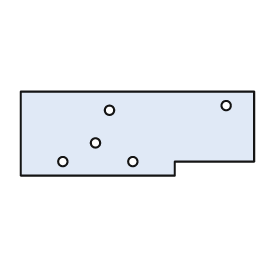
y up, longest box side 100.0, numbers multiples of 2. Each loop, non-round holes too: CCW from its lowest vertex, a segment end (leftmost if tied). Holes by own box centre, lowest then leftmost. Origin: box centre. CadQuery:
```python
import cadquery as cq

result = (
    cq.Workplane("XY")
    .moveTo(-50.0, -18.0)
    .lineTo(16.0, -18.0)
    .lineTo(16.0, -12.0)
    .lineTo(50.0, -12.0)
    .lineTo(50.0, 18.0)
    .lineTo(-50.0, 18.0)
    .close()
    .moveTo(-32.0, -12.0)
    .circle(2.0)
    .moveTo(-2.0, -12.0)
    .circle(2.0)
    .moveTo(-18.0, -4.0)
    .circle(2.0)
    .moveTo(-12.0, 10.0)
    .circle(2.0)
    .moveTo(38.0, 12.0)
    .circle(2.0)
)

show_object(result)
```